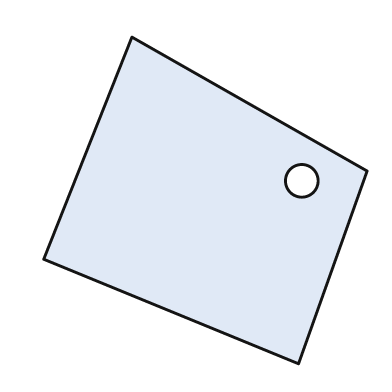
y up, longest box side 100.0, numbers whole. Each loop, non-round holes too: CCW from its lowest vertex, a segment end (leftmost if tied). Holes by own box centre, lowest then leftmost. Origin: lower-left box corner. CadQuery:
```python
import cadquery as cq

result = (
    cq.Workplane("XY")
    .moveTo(78.0, 0.0)
    .lineTo(99.0, 59.0)
    .lineTo(27.0, 100.0)
    .lineTo(0.0, 32.0)
    .close()
    .moveTo(79.0, 56.0)
    .circle(5.0)
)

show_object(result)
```